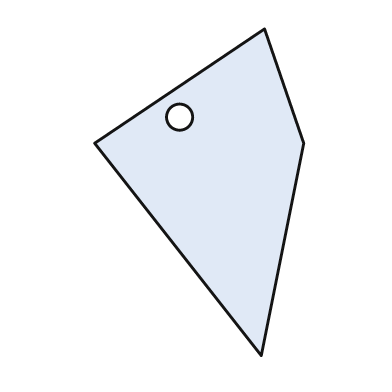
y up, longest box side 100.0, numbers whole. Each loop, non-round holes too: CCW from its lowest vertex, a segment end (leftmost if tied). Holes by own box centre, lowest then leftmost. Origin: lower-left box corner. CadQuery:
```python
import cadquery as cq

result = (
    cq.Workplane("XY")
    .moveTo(51.0, 0.0)
    .lineTo(64.0, 65.0)
    .lineTo(52.0, 100.0)
    .lineTo(0.0, 65.0)
    .close()
    .moveTo(26.0, 73.0)
    .circle(4.0)
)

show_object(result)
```